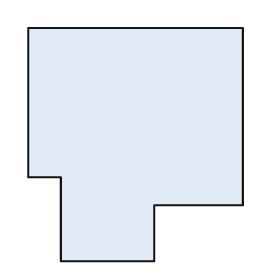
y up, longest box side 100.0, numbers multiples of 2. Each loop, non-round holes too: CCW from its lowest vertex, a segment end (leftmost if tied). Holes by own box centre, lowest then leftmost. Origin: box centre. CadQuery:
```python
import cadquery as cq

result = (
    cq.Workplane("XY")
    .moveTo(-32.0, -50.0)
    .lineTo(8.0, -50.0)
    .lineTo(8.0, -26.0)
    .lineTo(46.0, -26.0)
    .lineTo(46.0, 50.0)
    .lineTo(-46.0, 50.0)
    .lineTo(-46.0, -14.0)
    .lineTo(-32.0, -14.0)
    .close()
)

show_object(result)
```